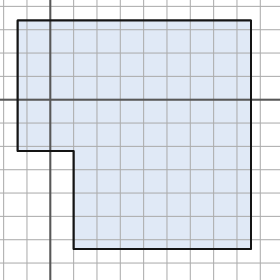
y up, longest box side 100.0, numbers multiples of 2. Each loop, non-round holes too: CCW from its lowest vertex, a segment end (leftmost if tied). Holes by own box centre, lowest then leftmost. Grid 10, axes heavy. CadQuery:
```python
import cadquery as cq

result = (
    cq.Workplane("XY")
    .moveTo(10.0, -64.0)
    .lineTo(86.0, -64.0)
    .lineTo(86.0, 34.0)
    .lineTo(-14.0, 34.0)
    .lineTo(-14.0, -22.0)
    .lineTo(10.0, -22.0)
    .close()
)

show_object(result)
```